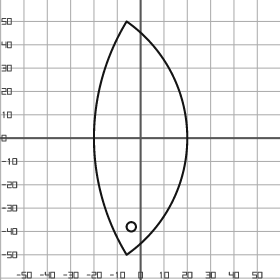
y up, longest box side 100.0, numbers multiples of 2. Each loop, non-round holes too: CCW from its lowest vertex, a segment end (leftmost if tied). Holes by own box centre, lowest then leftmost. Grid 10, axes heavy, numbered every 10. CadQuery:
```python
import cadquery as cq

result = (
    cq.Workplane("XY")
    .moveTo(-6.0, -50.0)
    .threePointArc((20.0, 0.0), (-6.0, 50.0))
    .threePointArc((-20.0, 0.0), (-6.0, -50.0))
    .close()
    .moveTo(-4.0, -38.0)
    .circle(2.0)
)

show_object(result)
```